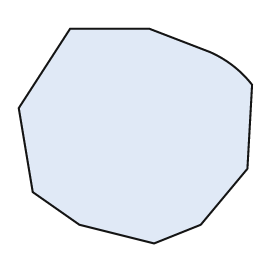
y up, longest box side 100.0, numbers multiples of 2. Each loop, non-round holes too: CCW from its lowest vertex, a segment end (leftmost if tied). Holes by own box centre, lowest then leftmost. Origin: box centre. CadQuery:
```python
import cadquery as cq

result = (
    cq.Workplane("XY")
    .moveTo(8.0, -46.0)
    .lineTo(28.0, -38.0)
    .lineTo(48.0, -14.0)
    .lineTo(50.0, 22.0)
    .threePointArc((42.0, 30.0), (32.0, 36.0))
    .lineTo(6.0, 46.0)
    .lineTo(-28.0, 46.0)
    .lineTo(-50.0, 12.0)
    .lineTo(-44.0, -24.0)
    .lineTo(-24.0, -38.0)
    .close()
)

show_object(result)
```